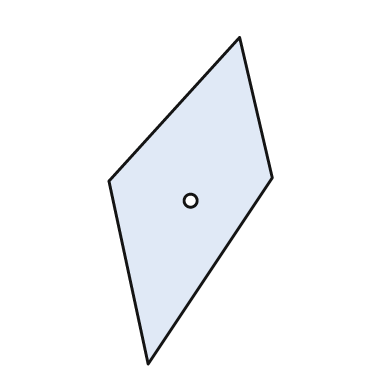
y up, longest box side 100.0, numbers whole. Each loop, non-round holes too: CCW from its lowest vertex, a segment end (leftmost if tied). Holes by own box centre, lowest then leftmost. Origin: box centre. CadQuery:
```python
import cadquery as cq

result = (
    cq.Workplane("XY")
    .moveTo(-13.0, -50.0)
    .lineTo(25.0, 7.0)
    .lineTo(15.0, 50.0)
    .lineTo(-25.0, 6.0)
    .close()
    .moveTo(0.0, 0.0)
    .circle(2.0)
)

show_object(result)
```